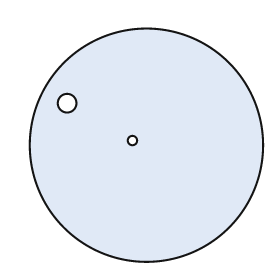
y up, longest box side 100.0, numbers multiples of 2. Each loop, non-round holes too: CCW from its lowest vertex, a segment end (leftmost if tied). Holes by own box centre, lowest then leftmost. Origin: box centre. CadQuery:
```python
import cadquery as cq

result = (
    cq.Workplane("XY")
    .moveTo(0.0, 0.0)
    .circle(50.0)
    .moveTo(-6.0, 2.0)
    .circle(2.0)
    .moveTo(-34.0, 18.0)
    .circle(4.0)
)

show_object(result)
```